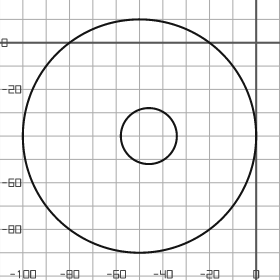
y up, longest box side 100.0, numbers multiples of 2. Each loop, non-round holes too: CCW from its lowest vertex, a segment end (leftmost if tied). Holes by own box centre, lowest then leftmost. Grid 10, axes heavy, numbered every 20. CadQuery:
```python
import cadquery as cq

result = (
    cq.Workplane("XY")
    .moveTo(-50.0, -40.0)
    .circle(50.0)
    .moveTo(-46.0, -40.0)
    .circle(12.0)
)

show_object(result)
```